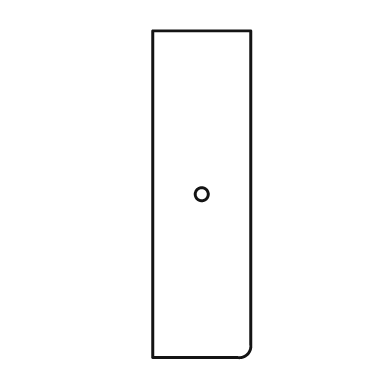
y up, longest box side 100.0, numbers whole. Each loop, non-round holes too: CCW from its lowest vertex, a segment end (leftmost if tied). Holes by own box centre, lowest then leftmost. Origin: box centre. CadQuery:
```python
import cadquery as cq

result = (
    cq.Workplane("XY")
    .moveTo(-15.0, -50.0)
    .lineTo(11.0, -50.0)
    .threePointArc((14.0, -49.0), (15.0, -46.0))
    .lineTo(15.0, 50.0)
    .lineTo(-15.0, 50.0)
    .close()
    .moveTo(0.0, 0.0)
    .circle(2.0)
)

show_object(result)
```